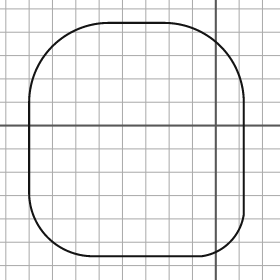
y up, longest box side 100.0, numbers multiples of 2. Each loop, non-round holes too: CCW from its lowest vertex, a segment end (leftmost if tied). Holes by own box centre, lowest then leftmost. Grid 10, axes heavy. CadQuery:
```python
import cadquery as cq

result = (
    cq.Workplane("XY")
    .moveTo(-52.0, -56.0)
    .lineTo(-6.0, -56.0)
    .threePointArc((6.0, -50.0), (12.0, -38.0))
    .lineTo(12.0, 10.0)
    .threePointArc((2.0, 34.0), (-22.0, 44.0))
    .lineTo(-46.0, 44.0)
    .threePointArc((-70.0, 34.0), (-80.0, 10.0))
    .lineTo(-80.0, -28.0)
    .threePointArc((-72.0, -48.0), (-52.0, -56.0))
    .close()
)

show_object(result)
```